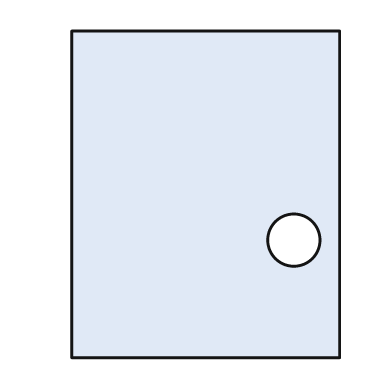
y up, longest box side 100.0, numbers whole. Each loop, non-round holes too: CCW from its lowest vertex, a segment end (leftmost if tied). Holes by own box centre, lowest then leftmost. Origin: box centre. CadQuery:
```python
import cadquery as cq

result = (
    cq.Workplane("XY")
    .moveTo(-41.0, -50.0)
    .lineTo(41.0, -50.0)
    .lineTo(41.0, 50.0)
    .lineTo(-41.0, 50.0)
    .close()
    .moveTo(27.0, -14.0)
    .circle(8.0)
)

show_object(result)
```